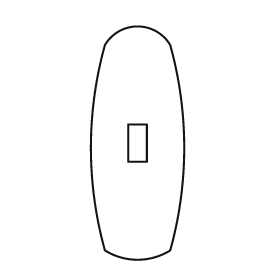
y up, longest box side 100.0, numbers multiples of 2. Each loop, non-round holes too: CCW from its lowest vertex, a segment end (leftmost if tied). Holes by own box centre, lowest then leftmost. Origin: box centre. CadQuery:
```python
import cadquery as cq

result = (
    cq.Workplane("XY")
    .moveTo(-14.0, -46.0)
    .threePointArc((0.0, -50.0), (14.0, -46.0))
    .threePointArc((20.0, -2.0), (14.0, 42.0))
    .threePointArc((0.0, 50.0), (-14.0, 42.0))
    .threePointArc((-20.0, -2.0), (-14.0, -46.0))
    .close()
    .moveTo(-4.0, -8.0)
    .lineTo(4.0, -8.0)
    .lineTo(4.0, 8.0)
    .lineTo(-4.0, 8.0)
    .close()
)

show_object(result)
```